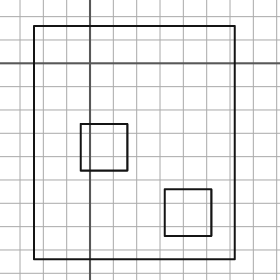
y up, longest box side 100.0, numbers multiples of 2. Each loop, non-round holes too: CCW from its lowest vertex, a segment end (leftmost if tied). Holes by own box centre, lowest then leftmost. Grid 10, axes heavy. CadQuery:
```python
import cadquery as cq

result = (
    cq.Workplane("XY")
    .moveTo(-24.0, -84.0)
    .lineTo(62.0, -84.0)
    .lineTo(62.0, 16.0)
    .lineTo(-24.0, 16.0)
    .close()
    .moveTo(32.0, -74.0)
    .lineTo(52.0, -74.0)
    .lineTo(52.0, -54.0)
    .lineTo(32.0, -54.0)
    .close()
    .moveTo(-4.0, -46.0)
    .lineTo(16.0, -46.0)
    .lineTo(16.0, -26.0)
    .lineTo(-4.0, -26.0)
    .close()
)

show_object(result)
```